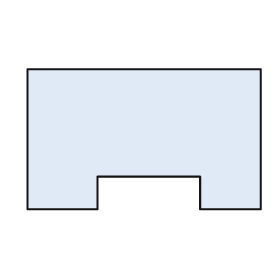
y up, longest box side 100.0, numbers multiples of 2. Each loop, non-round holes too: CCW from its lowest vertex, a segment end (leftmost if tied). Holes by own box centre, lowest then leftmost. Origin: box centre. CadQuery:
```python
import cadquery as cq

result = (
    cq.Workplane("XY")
    .moveTo(-50.0, -30.0)
    .lineTo(-20.0, -30.0)
    .lineTo(-20.0, -16.0)
    .lineTo(24.0, -16.0)
    .lineTo(24.0, -30.0)
    .lineTo(50.0, -30.0)
    .lineTo(50.0, 30.0)
    .lineTo(-50.0, 30.0)
    .close()
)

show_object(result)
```